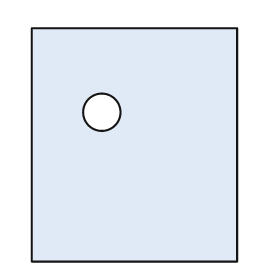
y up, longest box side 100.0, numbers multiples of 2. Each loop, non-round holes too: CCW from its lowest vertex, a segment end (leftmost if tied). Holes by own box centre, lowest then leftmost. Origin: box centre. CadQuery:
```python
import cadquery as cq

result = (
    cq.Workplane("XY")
    .moveTo(-44.0, -50.0)
    .lineTo(44.0, -50.0)
    .lineTo(44.0, 50.0)
    .lineTo(-44.0, 50.0)
    .close()
    .moveTo(-14.0, 14.0)
    .circle(8.0)
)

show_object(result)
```